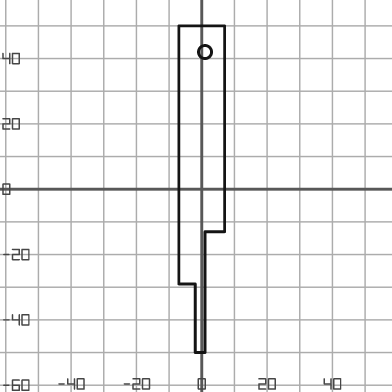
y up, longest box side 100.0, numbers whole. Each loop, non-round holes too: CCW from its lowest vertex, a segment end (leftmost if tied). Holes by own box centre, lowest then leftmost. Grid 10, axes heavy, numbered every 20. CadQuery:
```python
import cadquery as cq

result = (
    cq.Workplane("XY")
    .moveTo(-2.0, -50.0)
    .lineTo(1.0, -50.0)
    .lineTo(1.0, -13.0)
    .lineTo(7.0, -13.0)
    .lineTo(7.0, 50.0)
    .lineTo(-7.0, 50.0)
    .lineTo(-7.0, -29.0)
    .lineTo(-2.0, -29.0)
    .close()
    .moveTo(1.0, 42.0)
    .circle(2.0)
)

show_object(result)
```